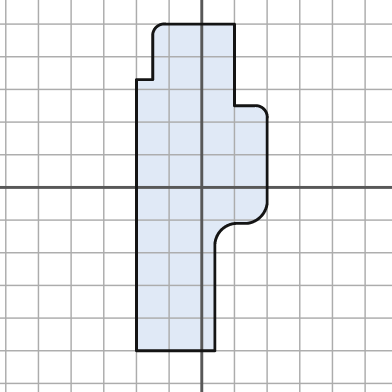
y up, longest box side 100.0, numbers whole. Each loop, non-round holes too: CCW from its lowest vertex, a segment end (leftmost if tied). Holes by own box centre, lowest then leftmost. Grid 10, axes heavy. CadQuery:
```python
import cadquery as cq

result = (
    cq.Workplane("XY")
    .moveTo(-20.0, -50.0)
    .lineTo(4.0, -50.0)
    .lineTo(4.0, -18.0)
    .threePointArc((6.0, -13.0), (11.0, -11.0))
    .lineTo(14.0, -11.0)
    .threePointArc((18.0, -9.0), (20.0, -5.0))
    .lineTo(20.0, 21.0)
    .threePointArc((19.0, 24.0), (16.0, 25.0))
    .lineTo(10.0, 25.0)
    .lineTo(10.0, 50.0)
    .lineTo(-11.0, 50.0)
    .threePointArc((-14.0, 49.0), (-15.0, 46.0))
    .lineTo(-15.0, 33.0)
    .lineTo(-20.0, 33.0)
    .close()
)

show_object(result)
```